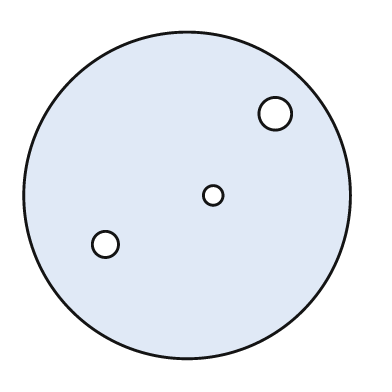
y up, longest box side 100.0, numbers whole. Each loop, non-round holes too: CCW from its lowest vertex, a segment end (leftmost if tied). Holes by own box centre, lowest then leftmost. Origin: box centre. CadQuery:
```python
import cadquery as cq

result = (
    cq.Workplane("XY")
    .moveTo(0.0, 0.0)
    .circle(50.0)
    .moveTo(-25.0, -15.0)
    .circle(4.0)
    .moveTo(8.0, 0.0)
    .circle(3.0)
    .moveTo(27.0, 25.0)
    .circle(5.0)
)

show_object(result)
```